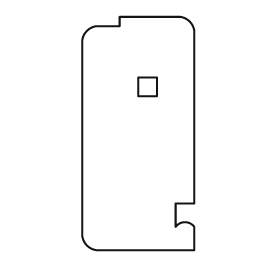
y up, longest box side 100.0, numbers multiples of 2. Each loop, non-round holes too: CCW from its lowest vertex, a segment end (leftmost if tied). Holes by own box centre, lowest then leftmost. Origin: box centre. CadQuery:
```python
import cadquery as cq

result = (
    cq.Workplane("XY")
    .moveTo(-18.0, -50.0)
    .lineTo(24.0, -50.0)
    .lineTo(24.0, -40.0)
    .threePointArc((20.0, -38.0), (16.0, -40.0))
    .lineTo(16.0, -30.0)
    .lineTo(24.0, -30.0)
    .lineTo(24.0, 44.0)
    .threePointArc((22.0, 48.0), (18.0, 50.0))
    .lineTo(-8.0, 50.0)
    .lineTo(-8.0, 46.0)
    .lineTo(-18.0, 46.0)
    .threePointArc((-22.0, 44.0), (-24.0, 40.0))
    .lineTo(-24.0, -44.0)
    .threePointArc((-22.0, -48.0), (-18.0, -50.0))
    .close()
    .moveTo(0.0, 16.0)
    .lineTo(8.0, 16.0)
    .lineTo(8.0, 24.0)
    .lineTo(0.0, 24.0)
    .close()
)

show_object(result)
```